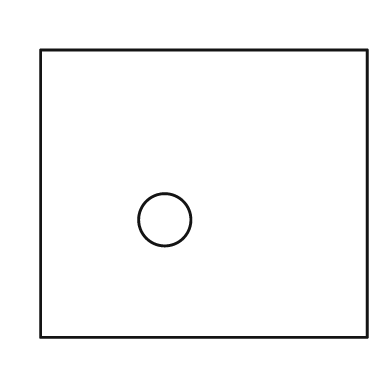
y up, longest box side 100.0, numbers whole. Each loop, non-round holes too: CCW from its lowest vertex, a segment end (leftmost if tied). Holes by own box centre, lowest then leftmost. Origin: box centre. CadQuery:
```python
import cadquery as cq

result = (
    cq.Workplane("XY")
    .moveTo(-50.0, -44.0)
    .lineTo(50.0, -44.0)
    .lineTo(50.0, 44.0)
    .lineTo(-50.0, 44.0)
    .close()
    .moveTo(-12.0, -8.0)
    .circle(8.0)
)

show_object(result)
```